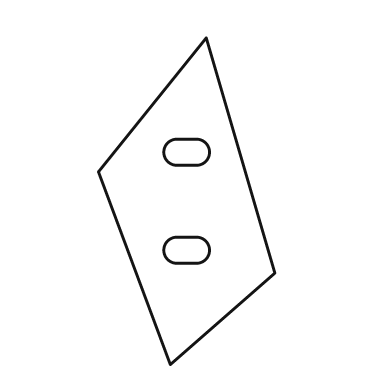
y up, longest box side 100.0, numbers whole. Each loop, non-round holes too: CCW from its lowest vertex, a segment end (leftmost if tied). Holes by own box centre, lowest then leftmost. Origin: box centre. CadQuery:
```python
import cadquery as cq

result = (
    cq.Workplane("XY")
    .moveTo(-5.0, -50.0)
    .lineTo(27.0, -22.0)
    .lineTo(6.0, 50.0)
    .lineTo(-27.0, 9.0)
    .close()
    .moveTo(-3.0, -19.0)
    .lineTo(3.0, -19.0)
    .threePointArc((7.0, -15.0), (3.0, -11.0))
    .lineTo(-3.0, -11.0)
    .threePointArc((-7.0, -15.0), (-3.0, -19.0))
    .close()
    .moveTo(-3.0, 11.0)
    .lineTo(3.0, 11.0)
    .threePointArc((7.0, 15.0), (3.0, 19.0))
    .lineTo(-3.0, 19.0)
    .threePointArc((-7.0, 15.0), (-3.0, 11.0))
    .close()
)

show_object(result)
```